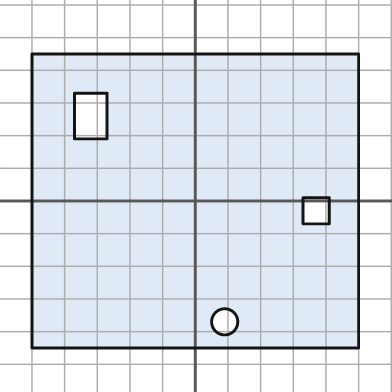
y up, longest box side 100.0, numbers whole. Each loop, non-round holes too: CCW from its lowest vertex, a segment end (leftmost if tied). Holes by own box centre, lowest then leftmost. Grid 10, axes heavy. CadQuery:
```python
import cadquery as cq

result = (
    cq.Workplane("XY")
    .moveTo(-50.0, -45.0)
    .lineTo(50.0, -45.0)
    .lineTo(50.0, 45.0)
    .lineTo(-50.0, 45.0)
    .close()
    .moveTo(9.0, -37.0)
    .circle(4.0)
    .moveTo(33.0, -7.0)
    .lineTo(41.0, -7.0)
    .lineTo(41.0, 1.0)
    .lineTo(33.0, 1.0)
    .close()
    .moveTo(-37.0, 19.0)
    .lineTo(-27.0, 19.0)
    .lineTo(-27.0, 33.0)
    .lineTo(-37.0, 33.0)
    .close()
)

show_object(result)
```